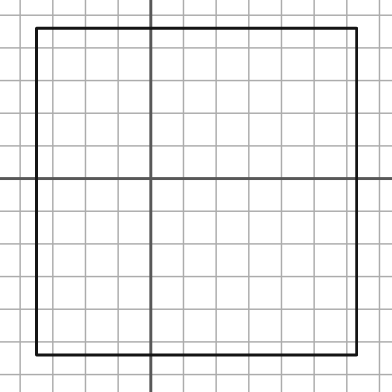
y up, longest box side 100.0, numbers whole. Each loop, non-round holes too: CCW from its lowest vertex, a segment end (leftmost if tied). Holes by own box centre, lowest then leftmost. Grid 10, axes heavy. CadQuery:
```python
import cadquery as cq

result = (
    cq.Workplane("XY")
    .moveTo(-35.0, -54.0)
    .lineTo(63.0, -54.0)
    .lineTo(63.0, 46.0)
    .lineTo(-35.0, 46.0)
    .close()
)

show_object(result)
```